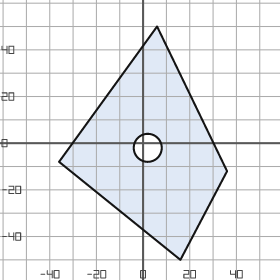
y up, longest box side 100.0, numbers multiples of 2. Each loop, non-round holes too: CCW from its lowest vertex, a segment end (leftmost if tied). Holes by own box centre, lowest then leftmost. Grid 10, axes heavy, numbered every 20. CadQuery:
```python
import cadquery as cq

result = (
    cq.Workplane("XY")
    .moveTo(16.0, -50.0)
    .lineTo(36.0, -12.0)
    .lineTo(6.0, 50.0)
    .lineTo(-36.0, -8.0)
    .close()
    .moveTo(2.0, -2.0)
    .circle(6.0)
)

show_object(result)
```